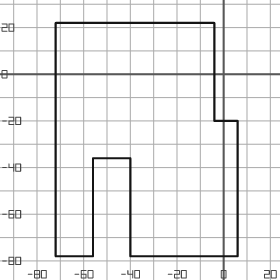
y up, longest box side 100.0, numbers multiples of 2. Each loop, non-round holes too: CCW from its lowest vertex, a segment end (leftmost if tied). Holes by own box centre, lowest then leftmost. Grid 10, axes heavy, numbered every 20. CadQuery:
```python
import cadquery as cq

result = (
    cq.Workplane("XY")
    .moveTo(-72.0, -78.0)
    .lineTo(-56.0, -78.0)
    .lineTo(-56.0, -36.0)
    .lineTo(-40.0, -36.0)
    .lineTo(-40.0, -78.0)
    .lineTo(6.0, -78.0)
    .lineTo(6.0, -20.0)
    .lineTo(-4.0, -20.0)
    .lineTo(-4.0, 22.0)
    .lineTo(-72.0, 22.0)
    .close()
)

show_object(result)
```